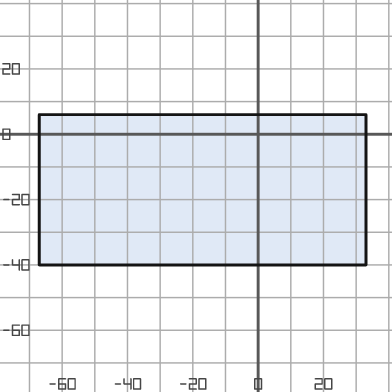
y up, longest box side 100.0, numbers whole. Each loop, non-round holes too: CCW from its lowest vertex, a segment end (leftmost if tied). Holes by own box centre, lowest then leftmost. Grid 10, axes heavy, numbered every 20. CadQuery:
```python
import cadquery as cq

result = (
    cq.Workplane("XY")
    .moveTo(-67.0, -40.0)
    .lineTo(33.0, -40.0)
    .lineTo(33.0, 6.0)
    .lineTo(-67.0, 6.0)
    .close()
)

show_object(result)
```